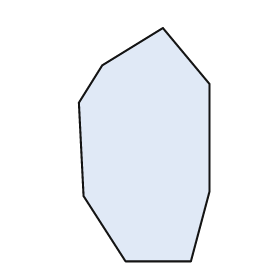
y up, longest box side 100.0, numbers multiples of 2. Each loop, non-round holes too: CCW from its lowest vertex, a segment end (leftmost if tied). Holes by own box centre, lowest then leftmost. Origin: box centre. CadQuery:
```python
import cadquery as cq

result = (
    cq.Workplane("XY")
    .moveTo(-8.0, -50.0)
    .lineTo(20.0, -50.0)
    .lineTo(28.0, -20.0)
    .lineTo(28.0, 26.0)
    .lineTo(8.0, 50.0)
    .lineTo(-18.0, 34.0)
    .lineTo(-28.0, 18.0)
    .lineTo(-26.0, -22.0)
    .close()
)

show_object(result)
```